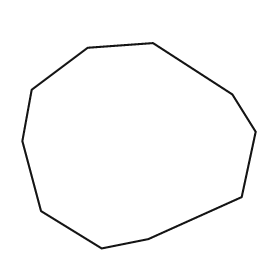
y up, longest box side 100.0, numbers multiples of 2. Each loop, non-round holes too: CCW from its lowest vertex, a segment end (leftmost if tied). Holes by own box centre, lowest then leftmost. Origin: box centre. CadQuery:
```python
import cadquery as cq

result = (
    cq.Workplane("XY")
    .moveTo(-16.0, -44.0)
    .lineTo(4.0, -40.0)
    .lineTo(44.0, -22.0)
    .lineTo(50.0, 6.0)
    .lineTo(40.0, 22.0)
    .lineTo(6.0, 44.0)
    .lineTo(-22.0, 42.0)
    .lineTo(-46.0, 24.0)
    .lineTo(-50.0, 2.0)
    .lineTo(-42.0, -28.0)
    .close()
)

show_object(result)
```